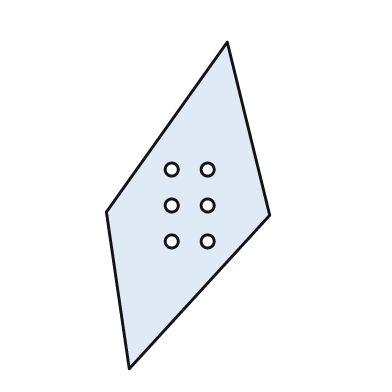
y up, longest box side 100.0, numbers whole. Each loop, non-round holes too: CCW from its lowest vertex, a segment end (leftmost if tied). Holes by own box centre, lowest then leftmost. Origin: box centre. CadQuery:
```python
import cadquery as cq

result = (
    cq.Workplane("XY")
    .moveTo(-18.0, -50.0)
    .lineTo(25.0, -3.0)
    .lineTo(12.0, 50.0)
    .lineTo(-25.0, -2.0)
    .close()
    .moveTo(-5.0, -11.0)
    .circle(2.0)
    .moveTo(6.0, -11.0)
    .circle(2.0)
    .moveTo(-5.0, 0.0)
    .circle(2.0)
    .moveTo(6.0, 0.0)
    .circle(2.0)
    .moveTo(-5.0, 11.0)
    .circle(2.0)
    .moveTo(6.0, 11.0)
    .circle(2.0)
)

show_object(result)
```